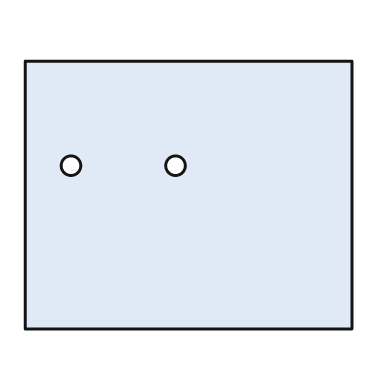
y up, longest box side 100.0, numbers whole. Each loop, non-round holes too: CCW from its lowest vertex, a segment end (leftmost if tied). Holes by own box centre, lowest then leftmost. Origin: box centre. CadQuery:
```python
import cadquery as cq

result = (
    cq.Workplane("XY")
    .moveTo(-50.0, -41.0)
    .lineTo(50.0, -41.0)
    .lineTo(50.0, 41.0)
    .lineTo(-50.0, 41.0)
    .close()
    .moveTo(-36.0, 9.0)
    .circle(3.0)
    .moveTo(-4.0, 9.0)
    .circle(3.0)
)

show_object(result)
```